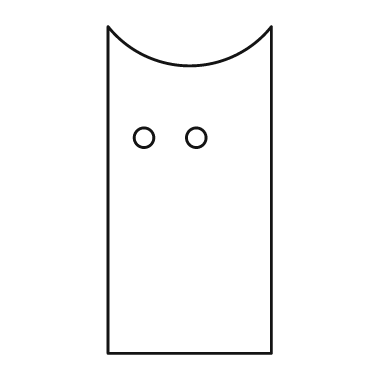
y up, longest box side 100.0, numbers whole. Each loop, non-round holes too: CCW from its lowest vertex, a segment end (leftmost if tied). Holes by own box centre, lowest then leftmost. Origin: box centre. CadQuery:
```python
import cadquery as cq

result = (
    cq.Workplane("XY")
    .moveTo(-25.0, -50.0)
    .lineTo(25.0, -50.0)
    .lineTo(25.0, 50.0)
    .threePointArc((0.0, 38.0), (-25.0, 50.0))
    .close()
    .moveTo(-14.0, 16.0)
    .circle(3.0)
    .moveTo(2.0, 16.0)
    .circle(3.0)
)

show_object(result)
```